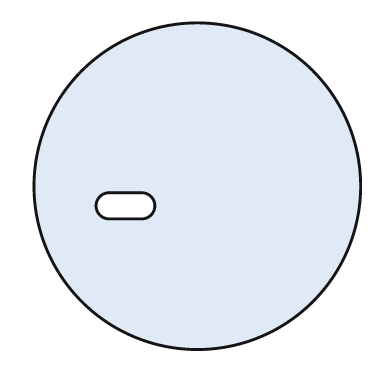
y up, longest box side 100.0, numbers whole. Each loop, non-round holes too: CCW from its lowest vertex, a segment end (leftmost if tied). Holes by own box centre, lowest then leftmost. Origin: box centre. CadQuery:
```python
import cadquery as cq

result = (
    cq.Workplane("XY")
    .moveTo(0.0, 0.0)
    .circle(50.0)
    .moveTo(-27.0, -10.0)
    .lineTo(-17.0, -10.0)
    .threePointArc((-13.0, -6.0), (-17.0, -2.0))
    .lineTo(-27.0, -2.0)
    .threePointArc((-31.0, -6.0), (-27.0, -10.0))
    .close()
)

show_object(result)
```